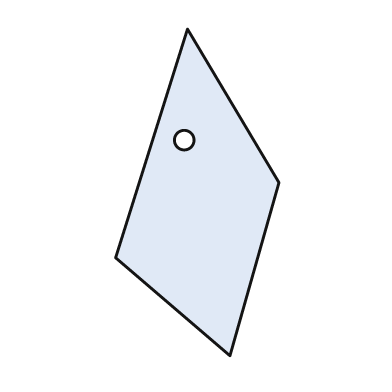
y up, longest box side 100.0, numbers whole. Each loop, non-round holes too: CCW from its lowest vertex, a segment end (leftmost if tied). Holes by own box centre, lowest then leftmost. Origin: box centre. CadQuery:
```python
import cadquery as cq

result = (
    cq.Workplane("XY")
    .moveTo(10.0, -50.0)
    .lineTo(25.0, 3.0)
    .lineTo(-3.0, 50.0)
    .lineTo(-25.0, -20.0)
    .close()
    .moveTo(-4.0, 16.0)
    .circle(3.0)
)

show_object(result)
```